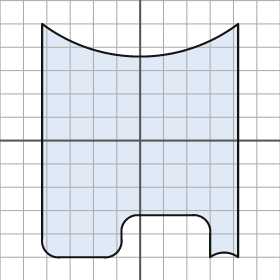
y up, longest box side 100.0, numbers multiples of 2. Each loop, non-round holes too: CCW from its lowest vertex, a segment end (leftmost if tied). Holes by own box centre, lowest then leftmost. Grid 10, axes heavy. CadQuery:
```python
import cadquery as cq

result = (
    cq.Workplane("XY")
    .moveTo(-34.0, -50.0)
    .lineTo(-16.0, -50.0)
    .threePointArc((-10.0, -48.0), (-8.0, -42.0))
    .lineTo(-8.0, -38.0)
    .threePointArc((-6.0, -34.0), (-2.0, -32.0))
    .lineTo(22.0, -32.0)
    .threePointArc((28.0, -34.0), (30.0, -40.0))
    .lineTo(30.0, -50.0)
    .threePointArc((36.0, -48.0), (42.0, -50.0))
    .lineTo(42.0, 50.0)
    .threePointArc((0.0, 36.0), (-42.0, 50.0))
    .lineTo(-42.0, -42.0)
    .threePointArc((-40.0, -48.0), (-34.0, -50.0))
    .close()
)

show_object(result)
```